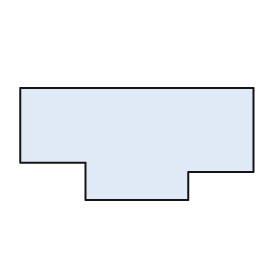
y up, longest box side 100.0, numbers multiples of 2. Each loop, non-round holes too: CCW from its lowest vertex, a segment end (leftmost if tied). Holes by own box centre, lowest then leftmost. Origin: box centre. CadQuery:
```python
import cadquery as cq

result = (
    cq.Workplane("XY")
    .moveTo(-22.0, -24.0)
    .lineTo(22.0, -24.0)
    .lineTo(22.0, -12.0)
    .lineTo(50.0, -12.0)
    .lineTo(50.0, 24.0)
    .lineTo(-50.0, 24.0)
    .lineTo(-50.0, -8.0)
    .lineTo(-22.0, -8.0)
    .close()
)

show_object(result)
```